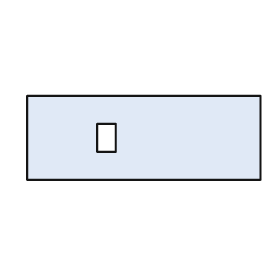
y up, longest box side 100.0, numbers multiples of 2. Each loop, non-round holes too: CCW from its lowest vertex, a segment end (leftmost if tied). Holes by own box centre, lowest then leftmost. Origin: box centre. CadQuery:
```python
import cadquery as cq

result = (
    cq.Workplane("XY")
    .moveTo(-50.0, -18.0)
    .lineTo(50.0, -18.0)
    .lineTo(50.0, 18.0)
    .lineTo(-50.0, 18.0)
    .close()
    .moveTo(-20.0, -6.0)
    .lineTo(-12.0, -6.0)
    .lineTo(-12.0, 6.0)
    .lineTo(-20.0, 6.0)
    .close()
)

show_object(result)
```